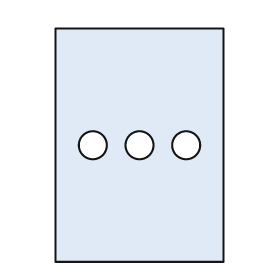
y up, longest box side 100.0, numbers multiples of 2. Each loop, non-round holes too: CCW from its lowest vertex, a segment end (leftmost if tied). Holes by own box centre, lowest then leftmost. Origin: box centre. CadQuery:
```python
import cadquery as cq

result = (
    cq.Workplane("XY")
    .moveTo(-36.0, -50.0)
    .lineTo(36.0, -50.0)
    .lineTo(36.0, 50.0)
    .lineTo(-36.0, 50.0)
    .close()
    .moveTo(-20.0, 0.0)
    .circle(6.0)
    .moveTo(0.0, 0.0)
    .circle(6.0)
    .moveTo(20.0, 0.0)
    .circle(6.0)
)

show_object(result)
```